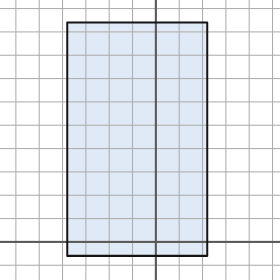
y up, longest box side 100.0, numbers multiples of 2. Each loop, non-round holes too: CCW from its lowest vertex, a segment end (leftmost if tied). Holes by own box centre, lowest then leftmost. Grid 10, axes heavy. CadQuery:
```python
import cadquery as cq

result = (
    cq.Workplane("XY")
    .moveTo(-38.0, -6.0)
    .lineTo(22.0, -6.0)
    .lineTo(22.0, 94.0)
    .lineTo(-38.0, 94.0)
    .close()
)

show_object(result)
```